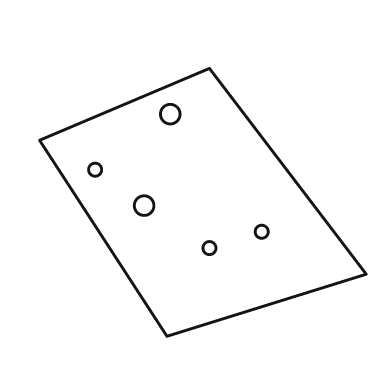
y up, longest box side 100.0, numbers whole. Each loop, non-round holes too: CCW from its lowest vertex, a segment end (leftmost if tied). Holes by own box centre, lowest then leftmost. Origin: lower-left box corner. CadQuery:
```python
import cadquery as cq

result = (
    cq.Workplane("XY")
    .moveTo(39.0, 0.0)
    .lineTo(100.0, 19.0)
    .lineTo(52.0, 82.0)
    .lineTo(0.0, 60.0)
    .close()
    .moveTo(52.0, 27.0)
    .circle(2.0)
    .moveTo(68.0, 32.0)
    .circle(2.0)
    .moveTo(32.0, 40.0)
    .circle(3.0)
    .moveTo(17.0, 51.0)
    .circle(2.0)
    .moveTo(40.0, 68.0)
    .circle(3.0)
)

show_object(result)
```